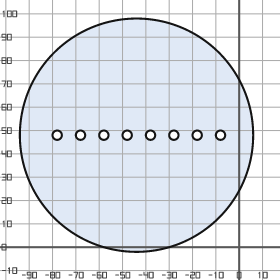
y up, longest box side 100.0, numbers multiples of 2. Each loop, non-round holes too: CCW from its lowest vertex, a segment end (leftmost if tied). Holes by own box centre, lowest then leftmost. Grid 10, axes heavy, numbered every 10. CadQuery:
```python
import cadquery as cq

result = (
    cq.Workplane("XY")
    .moveTo(-44.0, 48.0)
    .circle(50.0)
    .moveTo(-78.0, 48.0)
    .circle(2.0)
    .moveTo(-68.0, 48.0)
    .circle(2.0)
    .moveTo(-58.0, 48.0)
    .circle(2.0)
    .moveTo(-48.0, 48.0)
    .circle(2.0)
    .moveTo(-38.0, 48.0)
    .circle(2.0)
    .moveTo(-28.0, 48.0)
    .circle(2.0)
    .moveTo(-18.0, 48.0)
    .circle(2.0)
    .moveTo(-8.0, 48.0)
    .circle(2.0)
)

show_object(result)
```